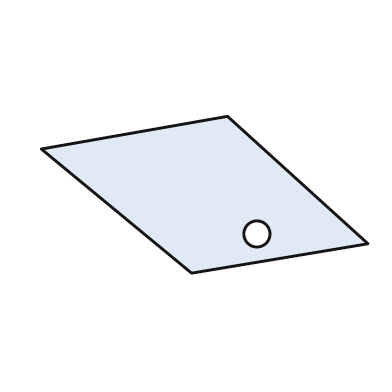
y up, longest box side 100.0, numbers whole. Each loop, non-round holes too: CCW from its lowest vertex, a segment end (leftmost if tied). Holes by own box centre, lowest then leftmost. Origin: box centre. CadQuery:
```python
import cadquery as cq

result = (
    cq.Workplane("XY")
    .moveTo(-4.0, -24.0)
    .lineTo(50.0, -15.0)
    .lineTo(7.0, 24.0)
    .lineTo(-50.0, 14.0)
    .close()
    .moveTo(16.0, -12.0)
    .circle(4.0)
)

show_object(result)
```